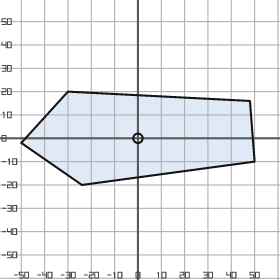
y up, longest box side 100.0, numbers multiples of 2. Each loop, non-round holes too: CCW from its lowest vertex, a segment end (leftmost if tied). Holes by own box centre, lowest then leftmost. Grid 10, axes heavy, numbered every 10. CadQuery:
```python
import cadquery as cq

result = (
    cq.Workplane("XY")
    .moveTo(-24.0, -20.0)
    .lineTo(50.0, -10.0)
    .lineTo(48.0, 16.0)
    .lineTo(-30.0, 20.0)
    .lineTo(-50.0, -2.0)
    .close()
    .moveTo(0.0, 0.0)
    .circle(2.0)
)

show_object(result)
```